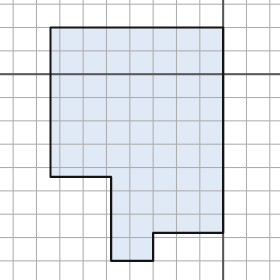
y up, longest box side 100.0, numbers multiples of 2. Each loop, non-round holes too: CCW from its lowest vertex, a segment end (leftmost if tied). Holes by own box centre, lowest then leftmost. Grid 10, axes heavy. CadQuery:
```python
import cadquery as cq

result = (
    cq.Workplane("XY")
    .moveTo(-48.0, -80.0)
    .lineTo(-30.0, -80.0)
    .lineTo(-30.0, -68.0)
    .lineTo(0.0, -68.0)
    .lineTo(0.0, 20.0)
    .lineTo(-74.0, 20.0)
    .lineTo(-74.0, -44.0)
    .lineTo(-48.0, -44.0)
    .close()
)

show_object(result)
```